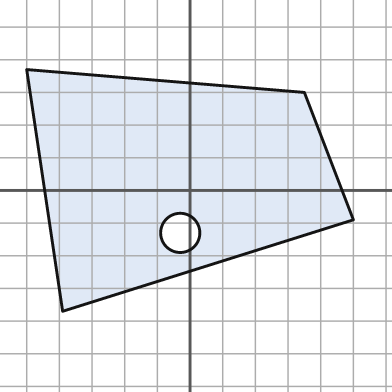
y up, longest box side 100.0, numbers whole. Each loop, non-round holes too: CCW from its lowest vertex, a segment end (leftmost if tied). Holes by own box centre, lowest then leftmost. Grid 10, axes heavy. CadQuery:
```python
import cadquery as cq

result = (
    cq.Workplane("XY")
    .moveTo(-39.0, -37.0)
    .lineTo(50.0, -9.0)
    .lineTo(35.0, 30.0)
    .lineTo(-50.0, 37.0)
    .close()
    .moveTo(-3.0, -13.0)
    .circle(6.0)
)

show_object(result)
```